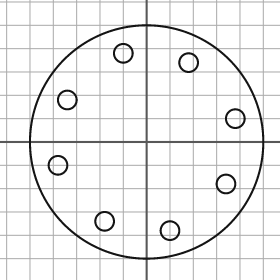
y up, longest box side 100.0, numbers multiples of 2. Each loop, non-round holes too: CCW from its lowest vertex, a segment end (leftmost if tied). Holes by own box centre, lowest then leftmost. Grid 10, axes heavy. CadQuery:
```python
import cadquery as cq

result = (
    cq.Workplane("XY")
    .moveTo(0.0, 0.0)
    .circle(50.0)
    .moveTo(10.0, -38.0)
    .circle(4.0)
    .moveTo(-18.0, -34.0)
    .circle(4.0)
    .moveTo(34.0, -18.0)
    .circle(4.0)
    .moveTo(-38.0, -10.0)
    .circle(4.0)
    .moveTo(38.0, 10.0)
    .circle(4.0)
    .moveTo(-34.0, 18.0)
    .circle(4.0)
    .moveTo(18.0, 34.0)
    .circle(4.0)
    .moveTo(-10.0, 38.0)
    .circle(4.0)
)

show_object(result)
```